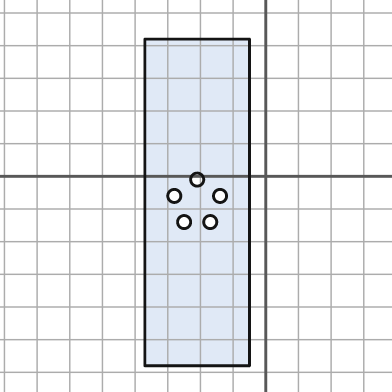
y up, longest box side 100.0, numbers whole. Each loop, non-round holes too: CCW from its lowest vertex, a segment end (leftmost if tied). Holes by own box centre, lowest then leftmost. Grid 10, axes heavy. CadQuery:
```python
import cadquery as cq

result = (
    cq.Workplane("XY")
    .moveTo(-37.0, -58.0)
    .lineTo(-5.0, -58.0)
    .lineTo(-5.0, 42.0)
    .lineTo(-37.0, 42.0)
    .close()
    .moveTo(-25.0, -14.0)
    .circle(2.0)
    .moveTo(-17.0, -14.0)
    .circle(2.0)
    .moveTo(-28.0, -6.0)
    .circle(2.0)
    .moveTo(-14.0, -6.0)
    .circle(2.0)
    .moveTo(-21.0, -1.0)
    .circle(2.0)
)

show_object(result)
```